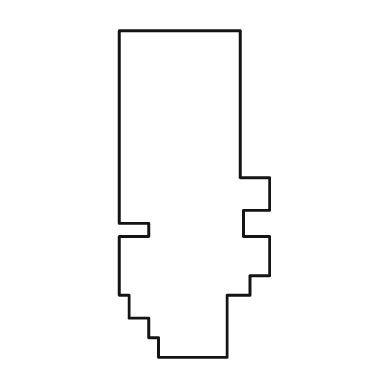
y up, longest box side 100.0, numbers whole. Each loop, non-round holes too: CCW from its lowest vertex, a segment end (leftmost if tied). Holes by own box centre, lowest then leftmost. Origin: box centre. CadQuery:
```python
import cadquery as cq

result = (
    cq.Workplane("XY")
    .moveTo(-11.0, -50.0)
    .lineTo(10.0, -50.0)
    .lineTo(10.0, -31.0)
    .lineTo(17.0, -31.0)
    .lineTo(17.0, -25.0)
    .lineTo(23.0, -25.0)
    .lineTo(23.0, -13.0)
    .lineTo(15.0, -13.0)
    .lineTo(15.0, -5.0)
    .lineTo(23.0, -5.0)
    .lineTo(23.0, 5.0)
    .lineTo(14.0, 5.0)
    .lineTo(14.0, 50.0)
    .lineTo(-23.0, 50.0)
    .lineTo(-23.0, -9.0)
    .lineTo(-14.0, -9.0)
    .lineTo(-14.0, -13.0)
    .lineTo(-23.0, -13.0)
    .lineTo(-23.0, -31.0)
    .lineTo(-20.0, -31.0)
    .lineTo(-20.0, -38.0)
    .lineTo(-14.0, -38.0)
    .lineTo(-14.0, -44.0)
    .lineTo(-11.0, -44.0)
    .close()
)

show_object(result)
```